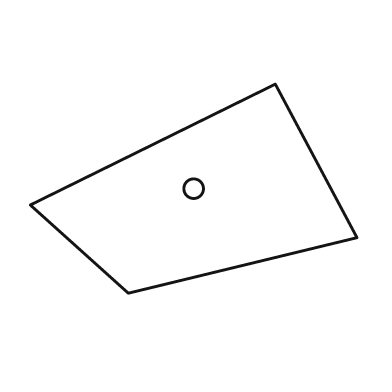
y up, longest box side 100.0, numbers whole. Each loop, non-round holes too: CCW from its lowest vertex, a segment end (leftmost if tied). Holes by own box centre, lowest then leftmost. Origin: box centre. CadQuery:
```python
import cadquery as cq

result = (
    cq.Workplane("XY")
    .moveTo(-20.0, -32.0)
    .lineTo(50.0, -15.0)
    .lineTo(25.0, 32.0)
    .lineTo(-50.0, -5.0)
    .close()
    .moveTo(0.0, 0.0)
    .circle(3.0)
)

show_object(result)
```